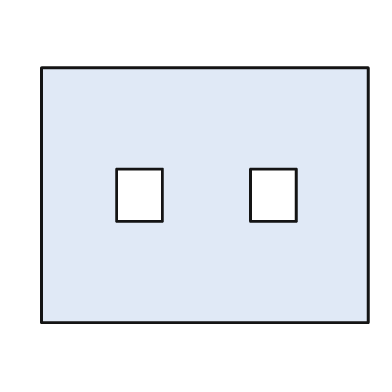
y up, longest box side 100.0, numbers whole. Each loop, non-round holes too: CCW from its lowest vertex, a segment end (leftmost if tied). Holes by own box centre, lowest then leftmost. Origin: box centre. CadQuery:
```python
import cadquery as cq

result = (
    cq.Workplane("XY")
    .moveTo(-50.0, -39.0)
    .lineTo(50.0, -39.0)
    .lineTo(50.0, 39.0)
    .lineTo(-50.0, 39.0)
    .close()
    .moveTo(-27.0, -8.0)
    .lineTo(-13.0, -8.0)
    .lineTo(-13.0, 8.0)
    .lineTo(-27.0, 8.0)
    .close()
    .moveTo(14.0, -8.0)
    .lineTo(28.0, -8.0)
    .lineTo(28.0, 8.0)
    .lineTo(14.0, 8.0)
    .close()
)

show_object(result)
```